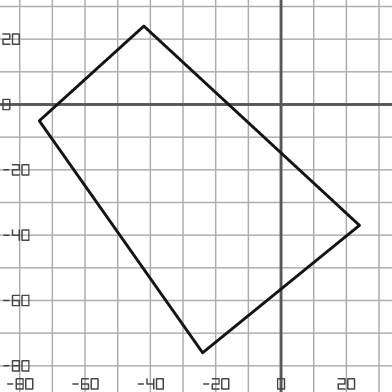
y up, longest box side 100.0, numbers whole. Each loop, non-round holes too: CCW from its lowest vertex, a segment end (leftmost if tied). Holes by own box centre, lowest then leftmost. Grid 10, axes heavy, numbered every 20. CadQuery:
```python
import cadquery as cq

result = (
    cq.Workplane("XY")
    .moveTo(-24.0, -76.0)
    .lineTo(24.0, -37.0)
    .lineTo(-42.0, 24.0)
    .lineTo(-74.0, -5.0)
    .close()
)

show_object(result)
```